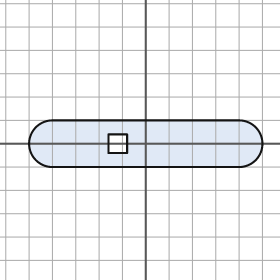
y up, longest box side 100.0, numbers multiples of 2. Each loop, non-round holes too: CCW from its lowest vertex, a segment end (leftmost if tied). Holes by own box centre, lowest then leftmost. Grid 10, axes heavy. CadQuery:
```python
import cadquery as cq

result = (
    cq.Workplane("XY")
    .moveTo(-40.0, -10.0)
    .lineTo(40.0, -10.0)
    .threePointArc((50.0, 0.0), (40.0, 10.0))
    .lineTo(-40.0, 10.0)
    .threePointArc((-50.0, 0.0), (-40.0, -10.0))
    .close()
    .moveTo(-16.0, -4.0)
    .lineTo(-8.0, -4.0)
    .lineTo(-8.0, 4.0)
    .lineTo(-16.0, 4.0)
    .close()
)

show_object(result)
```